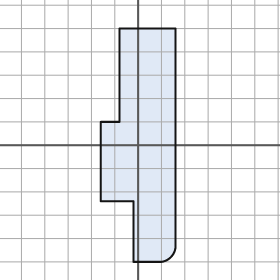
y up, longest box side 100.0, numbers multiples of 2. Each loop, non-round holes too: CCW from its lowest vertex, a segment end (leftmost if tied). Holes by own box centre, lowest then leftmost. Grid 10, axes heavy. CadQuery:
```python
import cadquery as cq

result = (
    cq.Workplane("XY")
    .moveTo(-2.0, -50.0)
    .lineTo(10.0, -50.0)
    .threePointArc((14.0, -48.0), (16.0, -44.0))
    .lineTo(16.0, 50.0)
    .lineTo(-8.0, 50.0)
    .lineTo(-8.0, 10.0)
    .lineTo(-16.0, 10.0)
    .lineTo(-16.0, -24.0)
    .lineTo(-2.0, -24.0)
    .close()
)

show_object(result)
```